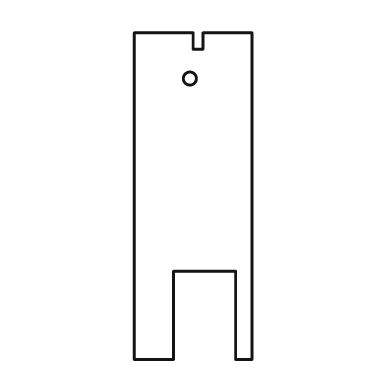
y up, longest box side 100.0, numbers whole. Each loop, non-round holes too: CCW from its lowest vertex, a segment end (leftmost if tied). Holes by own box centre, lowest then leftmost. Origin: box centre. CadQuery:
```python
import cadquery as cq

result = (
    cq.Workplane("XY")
    .moveTo(-18.0, -50.0)
    .lineTo(-6.0, -50.0)
    .lineTo(-6.0, -23.0)
    .lineTo(13.0, -23.0)
    .lineTo(13.0, -50.0)
    .lineTo(18.0, -50.0)
    .lineTo(18.0, 50.0)
    .lineTo(3.0, 50.0)
    .lineTo(3.0, 45.0)
    .lineTo(0.0, 45.0)
    .lineTo(0.0, 50.0)
    .lineTo(-18.0, 50.0)
    .close()
    .moveTo(-1.0, 36.0)
    .circle(2.0)
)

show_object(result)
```